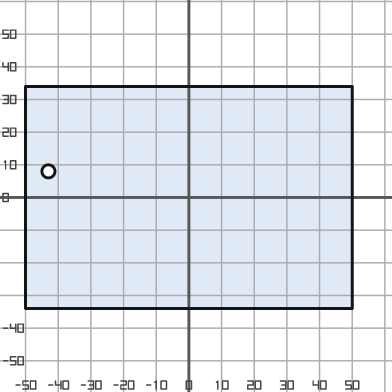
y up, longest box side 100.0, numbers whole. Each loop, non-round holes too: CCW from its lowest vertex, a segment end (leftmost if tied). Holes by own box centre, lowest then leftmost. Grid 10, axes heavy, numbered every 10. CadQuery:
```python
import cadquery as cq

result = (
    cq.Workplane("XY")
    .moveTo(-50.0, -34.0)
    .lineTo(50.0, -34.0)
    .lineTo(50.0, 34.0)
    .lineTo(-50.0, 34.0)
    .close()
    .moveTo(-43.0, 8.0)
    .circle(2.0)
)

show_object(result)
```